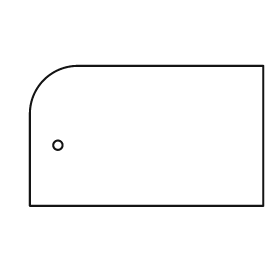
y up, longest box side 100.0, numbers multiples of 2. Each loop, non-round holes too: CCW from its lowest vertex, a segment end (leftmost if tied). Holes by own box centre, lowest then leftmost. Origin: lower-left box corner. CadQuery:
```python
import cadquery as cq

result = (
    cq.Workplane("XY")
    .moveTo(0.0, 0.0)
    .lineTo(100.0, 0.0)
    .lineTo(100.0, 60.0)
    .lineTo(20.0, 60.0)
    .threePointArc((6.0, 54.0), (0.0, 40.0))
    .close()
    .moveTo(12.0, 26.0)
    .circle(2.0)
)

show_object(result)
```